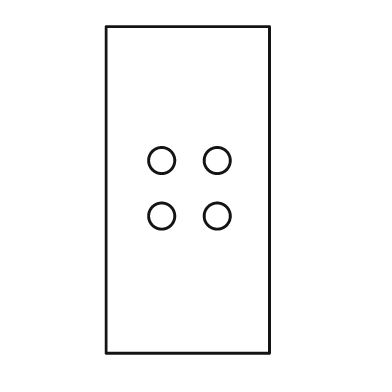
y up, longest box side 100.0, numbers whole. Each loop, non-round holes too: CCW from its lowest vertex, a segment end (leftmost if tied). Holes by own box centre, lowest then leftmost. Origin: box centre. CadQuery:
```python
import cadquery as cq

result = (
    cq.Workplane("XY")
    .moveTo(-25.0, -50.0)
    .lineTo(25.0, -50.0)
    .lineTo(25.0, 50.0)
    .lineTo(-25.0, 50.0)
    .close()
    .moveTo(-8.0, -8.0)
    .circle(4.0)
    .moveTo(9.0, -8.0)
    .circle(4.0)
    .moveTo(-8.0, 9.0)
    .circle(4.0)
    .moveTo(9.0, 9.0)
    .circle(4.0)
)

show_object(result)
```